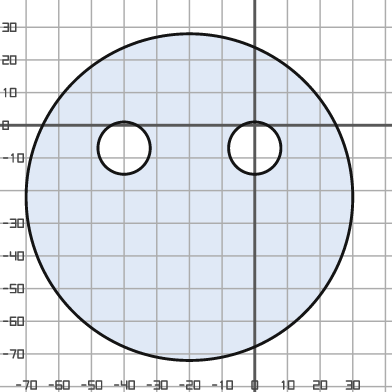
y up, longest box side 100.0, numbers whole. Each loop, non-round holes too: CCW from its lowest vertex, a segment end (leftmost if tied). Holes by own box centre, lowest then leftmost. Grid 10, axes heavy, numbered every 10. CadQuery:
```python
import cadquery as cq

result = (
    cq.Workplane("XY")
    .moveTo(-20.0, -22.0)
    .circle(50.0)
    .moveTo(-40.0, -7.0)
    .circle(8.0)
    .moveTo(0.0, -7.0)
    .circle(8.0)
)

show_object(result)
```